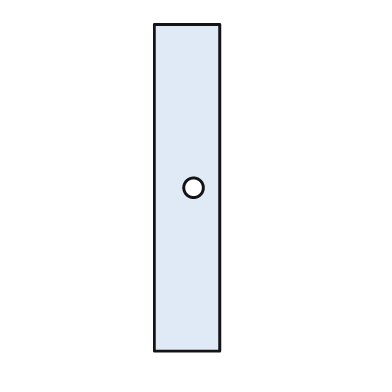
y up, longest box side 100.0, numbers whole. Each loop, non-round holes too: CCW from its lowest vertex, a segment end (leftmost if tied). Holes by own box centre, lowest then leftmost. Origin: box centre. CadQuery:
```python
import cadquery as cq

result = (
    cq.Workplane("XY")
    .moveTo(-10.0, -50.0)
    .lineTo(10.0, -50.0)
    .lineTo(10.0, 50.0)
    .lineTo(-10.0, 50.0)
    .close()
    .moveTo(2.0, 0.0)
    .circle(3.0)
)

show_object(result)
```